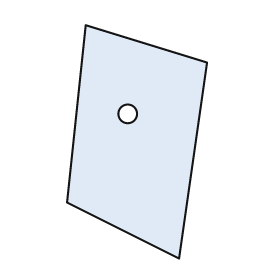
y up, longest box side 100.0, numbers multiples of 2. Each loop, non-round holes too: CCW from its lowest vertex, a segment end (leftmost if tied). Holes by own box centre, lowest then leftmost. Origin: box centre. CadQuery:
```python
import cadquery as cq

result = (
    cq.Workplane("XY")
    .moveTo(18.0, -50.0)
    .lineTo(30.0, 34.0)
    .lineTo(-22.0, 50.0)
    .lineTo(-30.0, -26.0)
    .close()
    .moveTo(-4.0, 12.0)
    .circle(4.0)
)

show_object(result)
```